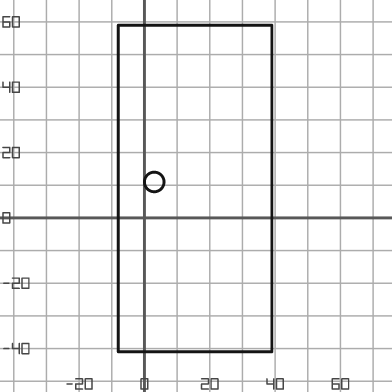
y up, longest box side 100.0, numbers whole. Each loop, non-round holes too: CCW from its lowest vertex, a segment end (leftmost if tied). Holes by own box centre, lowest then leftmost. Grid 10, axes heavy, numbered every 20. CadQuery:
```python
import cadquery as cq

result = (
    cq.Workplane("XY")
    .moveTo(-8.0, -41.0)
    .lineTo(39.0, -41.0)
    .lineTo(39.0, 59.0)
    .lineTo(-8.0, 59.0)
    .close()
    .moveTo(3.0, 11.0)
    .circle(3.0)
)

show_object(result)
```